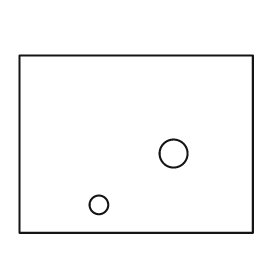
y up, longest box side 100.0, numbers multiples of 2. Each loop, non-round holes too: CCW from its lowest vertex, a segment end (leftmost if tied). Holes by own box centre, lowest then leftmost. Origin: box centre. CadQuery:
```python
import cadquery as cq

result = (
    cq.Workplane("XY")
    .moveTo(-50.0, -38.0)
    .lineTo(50.0, -38.0)
    .lineTo(50.0, 38.0)
    .lineTo(-50.0, 38.0)
    .close()
    .moveTo(-16.0, -26.0)
    .circle(4.0)
    .moveTo(16.0, -4.0)
    .circle(6.0)
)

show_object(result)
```